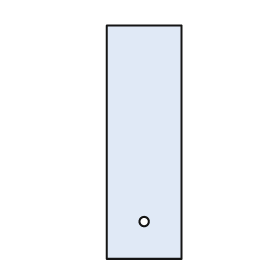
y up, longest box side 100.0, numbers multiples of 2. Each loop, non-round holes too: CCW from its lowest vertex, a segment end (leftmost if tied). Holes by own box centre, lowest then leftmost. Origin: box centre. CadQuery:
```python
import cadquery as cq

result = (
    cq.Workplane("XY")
    .moveTo(-16.0, -50.0)
    .lineTo(16.0, -50.0)
    .lineTo(16.0, 50.0)
    .lineTo(-16.0, 50.0)
    .close()
    .moveTo(0.0, -34.0)
    .circle(2.0)
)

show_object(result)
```